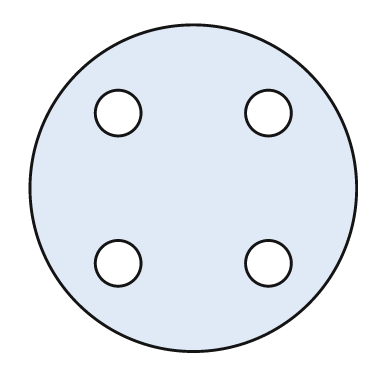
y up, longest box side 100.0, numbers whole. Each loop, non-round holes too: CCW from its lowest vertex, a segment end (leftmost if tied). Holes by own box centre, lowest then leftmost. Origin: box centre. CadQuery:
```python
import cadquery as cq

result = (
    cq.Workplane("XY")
    .moveTo(0.0, 0.0)
    .circle(50.0)
    .moveTo(-23.0, -23.0)
    .circle(7.0)
    .moveTo(23.0, -23.0)
    .circle(7.0)
    .moveTo(-23.0, 23.0)
    .circle(7.0)
    .moveTo(23.0, 23.0)
    .circle(7.0)
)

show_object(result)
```